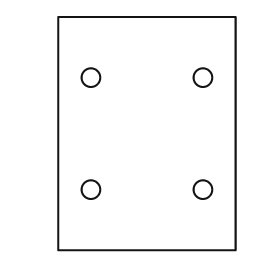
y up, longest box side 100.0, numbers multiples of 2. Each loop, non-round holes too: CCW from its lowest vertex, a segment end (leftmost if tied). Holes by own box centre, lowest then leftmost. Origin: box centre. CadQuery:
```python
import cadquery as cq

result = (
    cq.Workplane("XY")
    .moveTo(-38.0, -50.0)
    .lineTo(38.0, -50.0)
    .lineTo(38.0, 50.0)
    .lineTo(-38.0, 50.0)
    .close()
    .moveTo(-24.0, -24.0)
    .circle(4.0)
    .moveTo(24.0, -24.0)
    .circle(4.0)
    .moveTo(-24.0, 24.0)
    .circle(4.0)
    .moveTo(24.0, 24.0)
    .circle(4.0)
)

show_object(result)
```